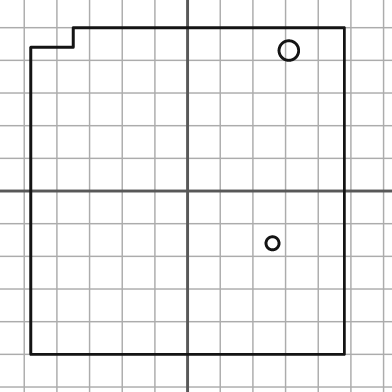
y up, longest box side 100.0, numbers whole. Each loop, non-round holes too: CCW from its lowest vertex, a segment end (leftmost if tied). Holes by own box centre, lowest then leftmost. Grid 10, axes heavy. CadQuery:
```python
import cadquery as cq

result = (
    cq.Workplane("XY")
    .moveTo(-48.0, -50.0)
    .lineTo(48.0, -50.0)
    .lineTo(48.0, 50.0)
    .lineTo(-35.0, 50.0)
    .lineTo(-35.0, 44.0)
    .lineTo(-48.0, 44.0)
    .close()
    .moveTo(26.0, -16.0)
    .circle(2.0)
    .moveTo(31.0, 43.0)
    .circle(3.0)
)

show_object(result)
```